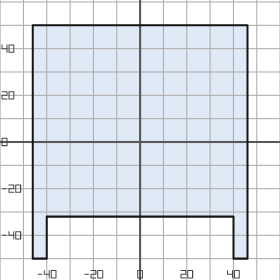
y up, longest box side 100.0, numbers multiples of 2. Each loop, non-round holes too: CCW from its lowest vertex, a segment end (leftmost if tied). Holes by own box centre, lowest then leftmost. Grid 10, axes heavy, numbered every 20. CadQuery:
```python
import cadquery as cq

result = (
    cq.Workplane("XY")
    .moveTo(-46.0, -50.0)
    .lineTo(-40.0, -50.0)
    .lineTo(-40.0, -32.0)
    .lineTo(40.0, -32.0)
    .lineTo(40.0, -50.0)
    .lineTo(46.0, -50.0)
    .lineTo(46.0, 50.0)
    .lineTo(-46.0, 50.0)
    .close()
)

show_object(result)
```